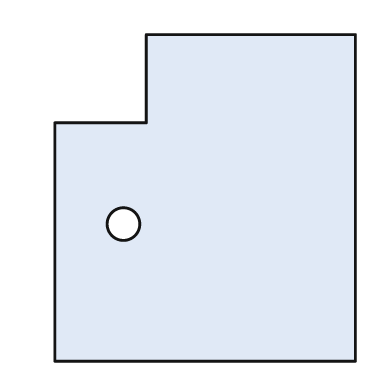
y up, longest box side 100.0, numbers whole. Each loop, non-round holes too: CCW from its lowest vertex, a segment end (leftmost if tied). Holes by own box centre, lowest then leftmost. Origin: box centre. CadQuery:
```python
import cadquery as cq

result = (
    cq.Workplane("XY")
    .moveTo(-46.0, -50.0)
    .lineTo(46.0, -50.0)
    .lineTo(46.0, 50.0)
    .lineTo(-18.0, 50.0)
    .lineTo(-18.0, 23.0)
    .lineTo(-46.0, 23.0)
    .close()
    .moveTo(-25.0, -8.0)
    .circle(5.0)
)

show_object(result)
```